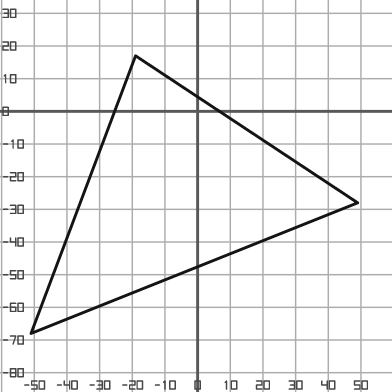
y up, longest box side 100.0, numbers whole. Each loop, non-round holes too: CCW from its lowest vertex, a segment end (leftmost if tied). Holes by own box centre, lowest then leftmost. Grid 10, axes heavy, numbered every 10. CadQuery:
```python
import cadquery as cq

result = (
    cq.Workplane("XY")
    .moveTo(-51.0, -68.0)
    .lineTo(49.0, -28.0)
    .lineTo(-19.0, 17.0)
    .close()
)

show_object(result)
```